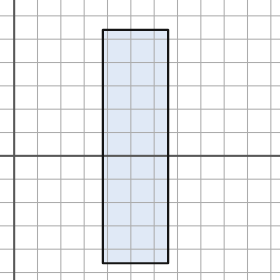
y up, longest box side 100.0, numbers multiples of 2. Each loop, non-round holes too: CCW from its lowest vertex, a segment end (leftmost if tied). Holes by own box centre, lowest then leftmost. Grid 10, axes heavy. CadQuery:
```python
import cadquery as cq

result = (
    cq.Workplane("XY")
    .moveTo(38.0, -46.0)
    .lineTo(66.0, -46.0)
    .lineTo(66.0, 54.0)
    .lineTo(38.0, 54.0)
    .close()
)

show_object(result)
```